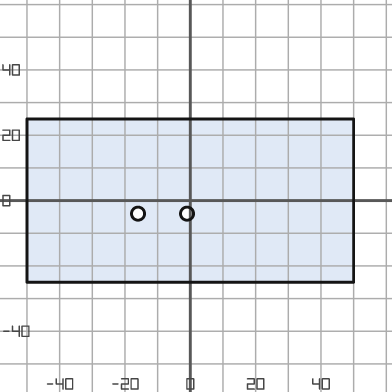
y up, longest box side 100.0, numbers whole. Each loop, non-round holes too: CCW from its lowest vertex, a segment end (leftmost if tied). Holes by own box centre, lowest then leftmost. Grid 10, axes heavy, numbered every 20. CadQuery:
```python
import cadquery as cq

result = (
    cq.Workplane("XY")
    .moveTo(-50.0, -25.0)
    .lineTo(50.0, -25.0)
    .lineTo(50.0, 25.0)
    .lineTo(-50.0, 25.0)
    .close()
    .moveTo(-16.0, -4.0)
    .circle(2.0)
    .moveTo(-1.0, -4.0)
    .circle(2.0)
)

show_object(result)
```